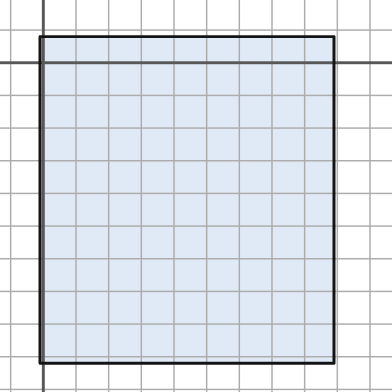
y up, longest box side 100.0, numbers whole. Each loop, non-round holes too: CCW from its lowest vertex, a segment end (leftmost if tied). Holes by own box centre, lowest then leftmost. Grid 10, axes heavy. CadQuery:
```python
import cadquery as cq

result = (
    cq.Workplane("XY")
    .moveTo(-1.0, -92.0)
    .lineTo(89.0, -92.0)
    .lineTo(89.0, 8.0)
    .lineTo(-1.0, 8.0)
    .close()
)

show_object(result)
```